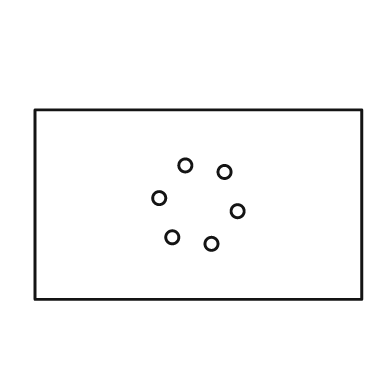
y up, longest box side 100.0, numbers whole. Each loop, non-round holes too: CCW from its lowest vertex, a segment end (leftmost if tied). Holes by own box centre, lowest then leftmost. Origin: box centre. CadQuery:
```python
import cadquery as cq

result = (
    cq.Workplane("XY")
    .moveTo(-50.0, -29.0)
    .lineTo(50.0, -29.0)
    .lineTo(50.0, 29.0)
    .lineTo(-50.0, 29.0)
    .close()
    .moveTo(4.0, -12.0)
    .circle(2.0)
    .moveTo(-8.0, -10.0)
    .circle(2.0)
    .moveTo(12.0, -2.0)
    .circle(2.0)
    .moveTo(-12.0, 2.0)
    .circle(2.0)
    .moveTo(8.0, 10.0)
    .circle(2.0)
    .moveTo(-4.0, 12.0)
    .circle(2.0)
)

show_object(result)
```